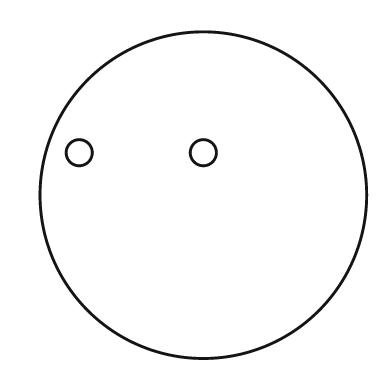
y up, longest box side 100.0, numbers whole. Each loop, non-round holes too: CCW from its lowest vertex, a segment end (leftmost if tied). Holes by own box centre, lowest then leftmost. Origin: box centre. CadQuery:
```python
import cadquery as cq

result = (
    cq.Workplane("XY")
    .moveTo(0.0, 0.0)
    .circle(50.0)
    .moveTo(-38.0, 13.0)
    .circle(4.0)
    .moveTo(0.0, 13.0)
    .circle(4.0)
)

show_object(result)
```